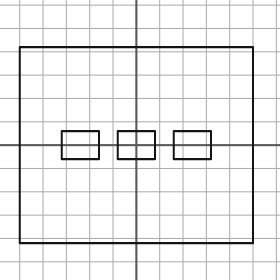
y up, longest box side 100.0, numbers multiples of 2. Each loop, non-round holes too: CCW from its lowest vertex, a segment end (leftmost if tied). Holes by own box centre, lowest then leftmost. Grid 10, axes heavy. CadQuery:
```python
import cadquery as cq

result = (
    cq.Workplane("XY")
    .moveTo(-50.0, -42.0)
    .lineTo(50.0, -42.0)
    .lineTo(50.0, 42.0)
    .lineTo(-50.0, 42.0)
    .close()
    .moveTo(-32.0, -6.0)
    .lineTo(-16.0, -6.0)
    .lineTo(-16.0, 6.0)
    .lineTo(-32.0, 6.0)
    .close()
    .moveTo(-8.0, -6.0)
    .lineTo(8.0, -6.0)
    .lineTo(8.0, 6.0)
    .lineTo(-8.0, 6.0)
    .close()
    .moveTo(16.0, -6.0)
    .lineTo(32.0, -6.0)
    .lineTo(32.0, 6.0)
    .lineTo(16.0, 6.0)
    .close()
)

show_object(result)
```